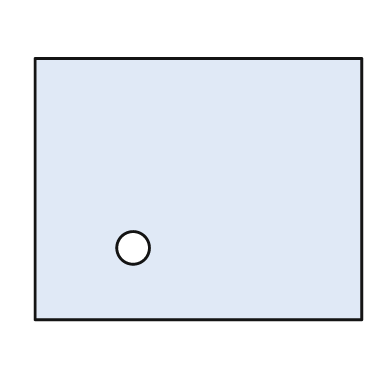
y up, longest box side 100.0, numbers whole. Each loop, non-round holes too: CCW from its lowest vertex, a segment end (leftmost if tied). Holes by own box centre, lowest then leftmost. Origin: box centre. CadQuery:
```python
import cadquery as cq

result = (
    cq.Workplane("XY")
    .moveTo(-50.0, -40.0)
    .lineTo(50.0, -40.0)
    .lineTo(50.0, 40.0)
    .lineTo(-50.0, 40.0)
    .close()
    .moveTo(-20.0, -18.0)
    .circle(5.0)
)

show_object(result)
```